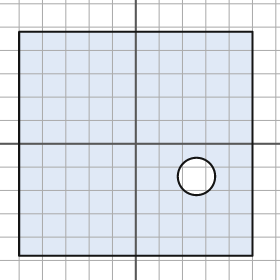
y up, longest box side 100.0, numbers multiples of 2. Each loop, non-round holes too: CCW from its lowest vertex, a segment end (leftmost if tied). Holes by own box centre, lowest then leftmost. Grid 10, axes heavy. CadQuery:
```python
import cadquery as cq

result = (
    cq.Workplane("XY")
    .moveTo(-50.0, -48.0)
    .lineTo(50.0, -48.0)
    .lineTo(50.0, 48.0)
    .lineTo(-50.0, 48.0)
    .close()
    .moveTo(26.0, -14.0)
    .circle(8.0)
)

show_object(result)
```